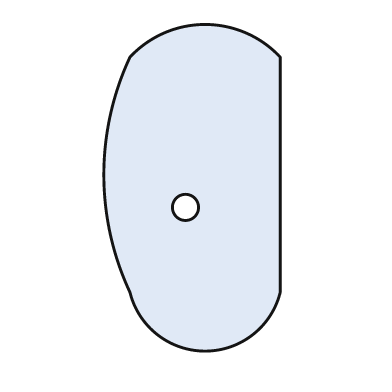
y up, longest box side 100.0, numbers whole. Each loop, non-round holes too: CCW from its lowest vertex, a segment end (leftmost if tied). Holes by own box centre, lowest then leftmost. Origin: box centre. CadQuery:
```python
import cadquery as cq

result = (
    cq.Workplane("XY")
    .moveTo(-19.0, -32.0)
    .threePointArc((4.0, -50.0), (27.0, -32.0))
    .lineTo(27.0, 40.0)
    .threePointArc((4.0, 50.0), (-19.0, 40.0))
    .threePointArc((-27.0, 4.0), (-19.0, -32.0))
    .close()
    .moveTo(-2.0, -6.0)
    .circle(4.0)
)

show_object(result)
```